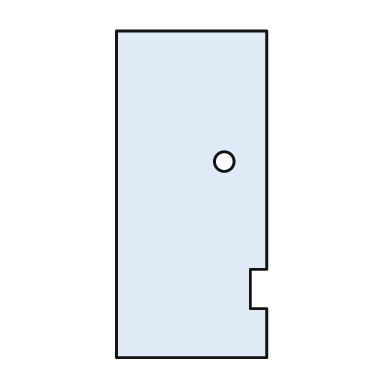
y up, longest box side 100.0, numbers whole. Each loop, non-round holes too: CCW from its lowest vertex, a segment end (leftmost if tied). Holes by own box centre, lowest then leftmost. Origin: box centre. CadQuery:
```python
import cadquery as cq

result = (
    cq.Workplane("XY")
    .moveTo(-23.0, -50.0)
    .lineTo(23.0, -50.0)
    .lineTo(23.0, -35.0)
    .lineTo(18.0, -35.0)
    .lineTo(18.0, -23.0)
    .lineTo(23.0, -23.0)
    .lineTo(23.0, 50.0)
    .lineTo(-23.0, 50.0)
    .close()
    .moveTo(10.0, 10.0)
    .circle(3.0)
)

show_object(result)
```